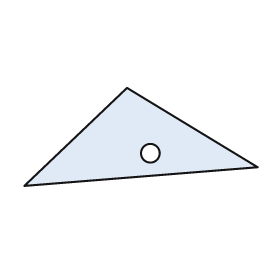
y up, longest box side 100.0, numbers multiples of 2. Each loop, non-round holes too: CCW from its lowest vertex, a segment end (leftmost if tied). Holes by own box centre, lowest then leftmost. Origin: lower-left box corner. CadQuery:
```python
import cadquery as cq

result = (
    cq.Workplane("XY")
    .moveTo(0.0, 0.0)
    .lineTo(100.0, 8.0)
    .lineTo(44.0, 42.0)
    .close()
    .moveTo(54.0, 14.0)
    .circle(4.0)
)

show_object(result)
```